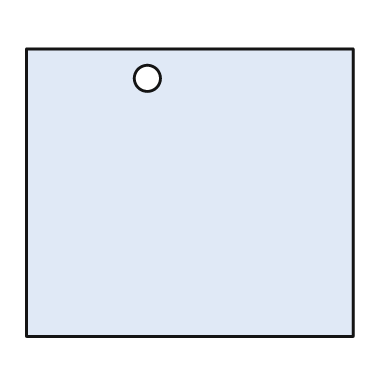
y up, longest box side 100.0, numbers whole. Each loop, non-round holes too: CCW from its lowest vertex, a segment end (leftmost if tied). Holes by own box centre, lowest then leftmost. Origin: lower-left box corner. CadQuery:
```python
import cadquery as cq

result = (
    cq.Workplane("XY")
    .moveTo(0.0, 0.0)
    .lineTo(100.0, 0.0)
    .lineTo(100.0, 88.0)
    .lineTo(0.0, 88.0)
    .close()
    .moveTo(37.0, 79.0)
    .circle(4.0)
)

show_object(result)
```